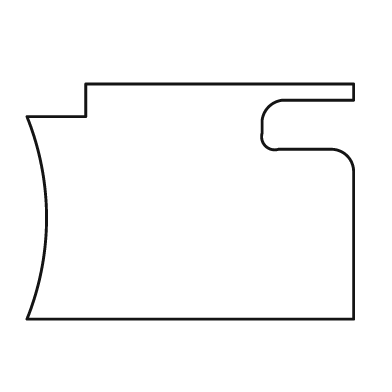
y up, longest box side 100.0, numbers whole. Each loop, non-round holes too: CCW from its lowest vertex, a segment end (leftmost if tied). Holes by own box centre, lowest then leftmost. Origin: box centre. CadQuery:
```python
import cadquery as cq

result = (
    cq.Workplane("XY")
    .moveTo(-50.0, -36.0)
    .lineTo(50.0, -36.0)
    .lineTo(50.0, 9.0)
    .threePointArc((48.0, 14.0), (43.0, 16.0))
    .lineTo(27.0, 16.0)
    .threePointArc((23.0, 17.0), (22.0, 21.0))
    .lineTo(22.0, 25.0)
    .threePointArc((24.0, 29.0), (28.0, 31.0))
    .lineTo(50.0, 31.0)
    .lineTo(50.0, 36.0)
    .lineTo(-32.0, 36.0)
    .lineTo(-32.0, 26.0)
    .lineTo(-50.0, 26.0)
    .threePointArc((-44.0, -5.0), (-50.0, -36.0))
    .close()
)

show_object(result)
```